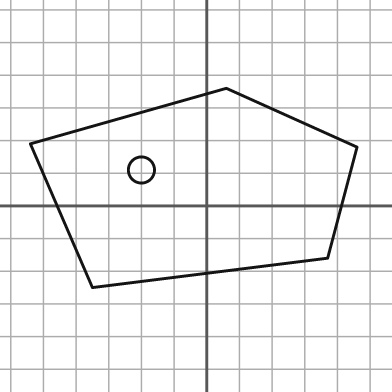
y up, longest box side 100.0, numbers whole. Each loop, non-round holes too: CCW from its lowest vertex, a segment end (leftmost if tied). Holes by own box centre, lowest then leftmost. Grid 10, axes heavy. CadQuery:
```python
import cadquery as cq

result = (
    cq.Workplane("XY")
    .moveTo(-35.0, -25.0)
    .lineTo(37.0, -16.0)
    .lineTo(46.0, 18.0)
    .lineTo(6.0, 36.0)
    .lineTo(-54.0, 19.0)
    .close()
    .moveTo(-20.0, 11.0)
    .circle(4.0)
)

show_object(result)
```